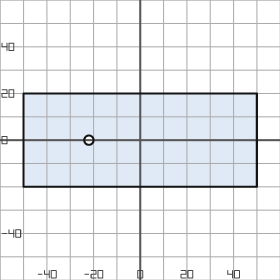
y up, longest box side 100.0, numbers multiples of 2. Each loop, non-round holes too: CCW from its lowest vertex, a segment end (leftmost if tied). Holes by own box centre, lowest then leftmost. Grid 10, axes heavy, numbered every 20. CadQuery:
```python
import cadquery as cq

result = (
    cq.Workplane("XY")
    .moveTo(-50.0, -20.0)
    .lineTo(50.0, -20.0)
    .lineTo(50.0, 20.0)
    .lineTo(-50.0, 20.0)
    .close()
    .moveTo(-22.0, 0.0)
    .circle(2.0)
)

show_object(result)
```